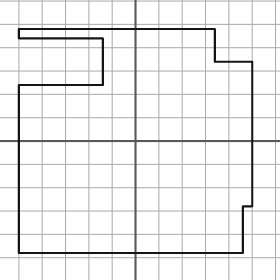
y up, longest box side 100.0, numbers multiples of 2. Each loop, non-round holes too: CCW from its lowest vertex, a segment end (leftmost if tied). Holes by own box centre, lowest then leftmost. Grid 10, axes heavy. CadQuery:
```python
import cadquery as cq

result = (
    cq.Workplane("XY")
    .moveTo(-50.0, -48.0)
    .lineTo(46.0, -48.0)
    .lineTo(46.0, -28.0)
    .lineTo(50.0, -28.0)
    .lineTo(50.0, 34.0)
    .lineTo(34.0, 34.0)
    .lineTo(34.0, 48.0)
    .lineTo(-50.0, 48.0)
    .lineTo(-50.0, 44.0)
    .lineTo(-14.0, 44.0)
    .lineTo(-14.0, 24.0)
    .lineTo(-50.0, 24.0)
    .close()
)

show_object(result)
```